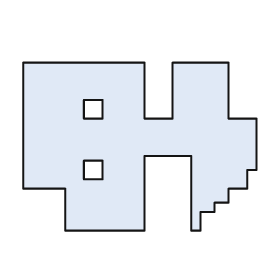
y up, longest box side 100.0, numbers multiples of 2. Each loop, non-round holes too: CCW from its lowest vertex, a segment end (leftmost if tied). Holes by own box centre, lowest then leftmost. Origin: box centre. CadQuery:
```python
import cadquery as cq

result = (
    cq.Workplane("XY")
    .moveTo(-32.0, -36.0)
    .lineTo(2.0, -36.0)
    .lineTo(2.0, -4.0)
    .lineTo(22.0, -4.0)
    .lineTo(22.0, -36.0)
    .lineTo(26.0, -36.0)
    .lineTo(26.0, -28.0)
    .lineTo(32.0, -28.0)
    .lineTo(32.0, -24.0)
    .lineTo(38.0, -24.0)
    .lineTo(38.0, -18.0)
    .lineTo(46.0, -18.0)
    .lineTo(46.0, -10.0)
    .lineTo(50.0, -10.0)
    .lineTo(50.0, 12.0)
    .lineTo(38.0, 12.0)
    .lineTo(38.0, 36.0)
    .lineTo(14.0, 36.0)
    .lineTo(14.0, 12.0)
    .lineTo(2.0, 12.0)
    .lineTo(2.0, 36.0)
    .lineTo(-50.0, 36.0)
    .lineTo(-50.0, -18.0)
    .lineTo(-32.0, -18.0)
    .close()
    .moveTo(-24.0, -14.0)
    .lineTo(-16.0, -14.0)
    .lineTo(-16.0, -6.0)
    .lineTo(-24.0, -6.0)
    .close()
    .moveTo(-24.0, 12.0)
    .lineTo(-16.0, 12.0)
    .lineTo(-16.0, 20.0)
    .lineTo(-24.0, 20.0)
    .close()
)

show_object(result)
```